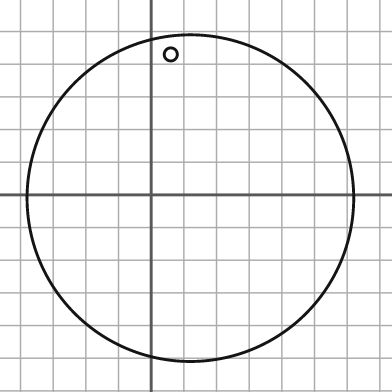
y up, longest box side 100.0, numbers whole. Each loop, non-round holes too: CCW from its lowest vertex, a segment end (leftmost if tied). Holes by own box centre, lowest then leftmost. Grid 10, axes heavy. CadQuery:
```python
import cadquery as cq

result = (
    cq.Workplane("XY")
    .moveTo(12.0, -1.0)
    .circle(50.0)
    .moveTo(6.0, 43.0)
    .circle(2.0)
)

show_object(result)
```